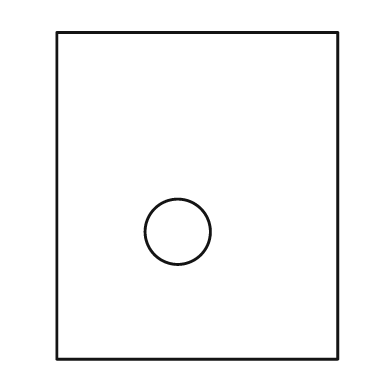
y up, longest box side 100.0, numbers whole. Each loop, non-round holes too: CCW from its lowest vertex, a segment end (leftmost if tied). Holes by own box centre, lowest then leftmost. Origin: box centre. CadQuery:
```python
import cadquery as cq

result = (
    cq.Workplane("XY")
    .moveTo(-43.0, -50.0)
    .lineTo(43.0, -50.0)
    .lineTo(43.0, 50.0)
    .lineTo(-43.0, 50.0)
    .close()
    .moveTo(-6.0, -11.0)
    .circle(10.0)
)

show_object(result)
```